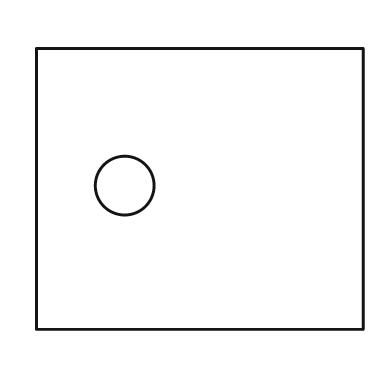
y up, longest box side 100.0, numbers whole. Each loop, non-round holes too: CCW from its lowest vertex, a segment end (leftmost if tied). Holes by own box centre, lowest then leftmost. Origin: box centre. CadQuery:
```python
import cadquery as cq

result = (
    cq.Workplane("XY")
    .moveTo(-50.0, -43.0)
    .lineTo(50.0, -43.0)
    .lineTo(50.0, 43.0)
    .lineTo(-50.0, 43.0)
    .close()
    .moveTo(-23.0, 1.0)
    .circle(9.0)
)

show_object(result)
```